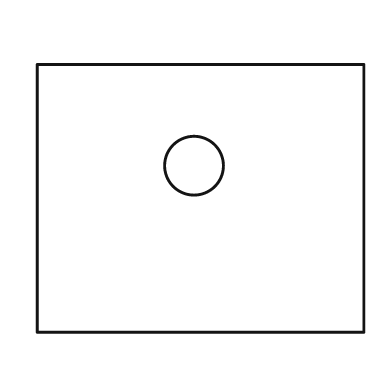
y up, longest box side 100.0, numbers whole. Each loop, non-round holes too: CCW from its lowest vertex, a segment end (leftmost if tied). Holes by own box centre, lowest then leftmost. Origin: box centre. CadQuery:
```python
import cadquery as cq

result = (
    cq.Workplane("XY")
    .moveTo(-50.0, -41.0)
    .lineTo(50.0, -41.0)
    .lineTo(50.0, 41.0)
    .lineTo(-50.0, 41.0)
    .close()
    .moveTo(-2.0, 10.0)
    .circle(9.0)
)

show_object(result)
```